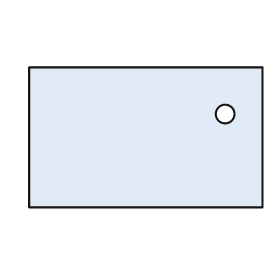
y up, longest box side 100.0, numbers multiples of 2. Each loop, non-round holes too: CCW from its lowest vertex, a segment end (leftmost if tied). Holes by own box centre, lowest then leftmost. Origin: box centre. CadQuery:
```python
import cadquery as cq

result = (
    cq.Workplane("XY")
    .moveTo(-50.0, -30.0)
    .lineTo(50.0, -30.0)
    .lineTo(50.0, 30.0)
    .lineTo(-50.0, 30.0)
    .close()
    .moveTo(34.0, 10.0)
    .circle(4.0)
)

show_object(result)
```